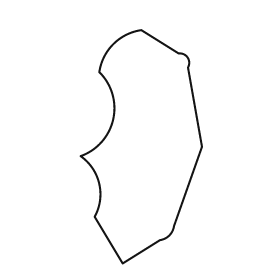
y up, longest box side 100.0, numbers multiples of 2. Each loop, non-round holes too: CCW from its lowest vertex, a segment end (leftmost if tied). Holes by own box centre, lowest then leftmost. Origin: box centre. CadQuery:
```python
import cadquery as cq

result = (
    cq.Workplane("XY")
    .moveTo(-8.0, -50.0)
    .lineTo(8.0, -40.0)
    .threePointArc((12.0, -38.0), (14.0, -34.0))
    .lineTo(26.0, 0.0)
    .lineTo(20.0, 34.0)
    .threePointArc((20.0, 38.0), (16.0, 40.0))
    .lineTo(0.0, 50.0)
    .threePointArc((-12.0, 44.0), (-18.0, 32.0))
    .threePointArc((-12.0, 12.0), (-26.0, -4.0))
    .threePointArc((-18.0, -16.0), (-20.0, -30.0))
    .close()
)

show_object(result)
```